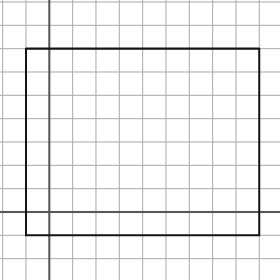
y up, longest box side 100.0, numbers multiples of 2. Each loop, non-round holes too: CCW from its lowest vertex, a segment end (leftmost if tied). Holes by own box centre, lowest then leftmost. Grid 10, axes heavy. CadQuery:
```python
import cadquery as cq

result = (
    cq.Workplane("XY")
    .moveTo(-10.0, -10.0)
    .lineTo(90.0, -10.0)
    .lineTo(90.0, 70.0)
    .lineTo(-10.0, 70.0)
    .close()
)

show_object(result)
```